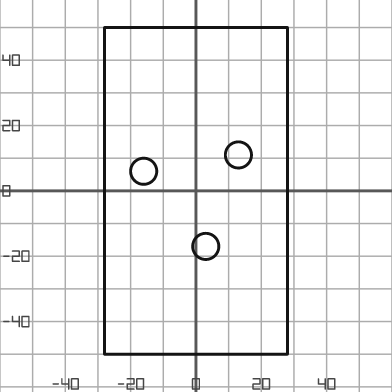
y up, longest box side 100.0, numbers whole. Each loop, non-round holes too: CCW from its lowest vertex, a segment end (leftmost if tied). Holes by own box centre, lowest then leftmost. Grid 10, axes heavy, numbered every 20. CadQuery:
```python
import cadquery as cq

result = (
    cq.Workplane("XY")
    .moveTo(-28.0, -50.0)
    .lineTo(28.0, -50.0)
    .lineTo(28.0, 50.0)
    .lineTo(-28.0, 50.0)
    .close()
    .moveTo(3.0, -17.0)
    .circle(4.0)
    .moveTo(-16.0, 6.0)
    .circle(4.0)
    .moveTo(13.0, 11.0)
    .circle(4.0)
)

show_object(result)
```